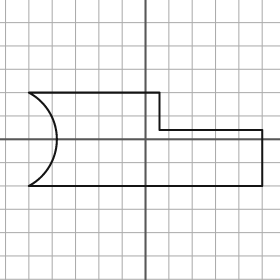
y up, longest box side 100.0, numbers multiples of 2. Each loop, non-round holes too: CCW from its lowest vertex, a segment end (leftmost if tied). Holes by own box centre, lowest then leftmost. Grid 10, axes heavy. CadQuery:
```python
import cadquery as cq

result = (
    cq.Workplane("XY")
    .moveTo(-50.0, -20.0)
    .lineTo(50.0, -20.0)
    .lineTo(50.0, 4.0)
    .lineTo(6.0, 4.0)
    .lineTo(6.0, 20.0)
    .lineTo(-50.0, 20.0)
    .threePointArc((-38.0, 0.0), (-50.0, -20.0))
    .close()
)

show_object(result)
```